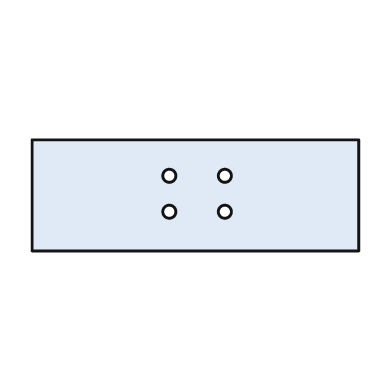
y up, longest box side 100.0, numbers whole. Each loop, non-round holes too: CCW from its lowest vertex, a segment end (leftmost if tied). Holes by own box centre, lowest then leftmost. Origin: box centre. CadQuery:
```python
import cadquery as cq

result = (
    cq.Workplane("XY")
    .moveTo(-50.0, -17.0)
    .lineTo(50.0, -17.0)
    .lineTo(50.0, 17.0)
    .lineTo(-50.0, 17.0)
    .close()
    .moveTo(-8.0, -5.0)
    .circle(2.0)
    .moveTo(9.0, -5.0)
    .circle(2.0)
    .moveTo(-8.0, 6.0)
    .circle(2.0)
    .moveTo(9.0, 6.0)
    .circle(2.0)
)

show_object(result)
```